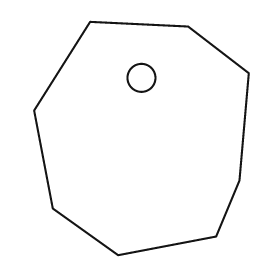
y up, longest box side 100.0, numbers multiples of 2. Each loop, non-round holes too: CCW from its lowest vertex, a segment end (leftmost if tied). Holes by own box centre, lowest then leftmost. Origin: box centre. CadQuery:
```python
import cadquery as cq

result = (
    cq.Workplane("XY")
    .moveTo(-10.0, -50.0)
    .lineTo(32.0, -42.0)
    .lineTo(42.0, -18.0)
    .lineTo(46.0, 28.0)
    .lineTo(20.0, 48.0)
    .lineTo(-22.0, 50.0)
    .lineTo(-46.0, 12.0)
    .lineTo(-38.0, -30.0)
    .close()
    .moveTo(0.0, 26.0)
    .circle(6.0)
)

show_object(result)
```